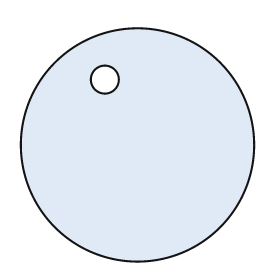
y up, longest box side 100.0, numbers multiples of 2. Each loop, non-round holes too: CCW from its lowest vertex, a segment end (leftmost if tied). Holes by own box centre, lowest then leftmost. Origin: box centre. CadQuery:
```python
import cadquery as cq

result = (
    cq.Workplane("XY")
    .moveTo(0.0, 0.0)
    .circle(50.0)
    .moveTo(-14.0, 28.0)
    .circle(6.0)
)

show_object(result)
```